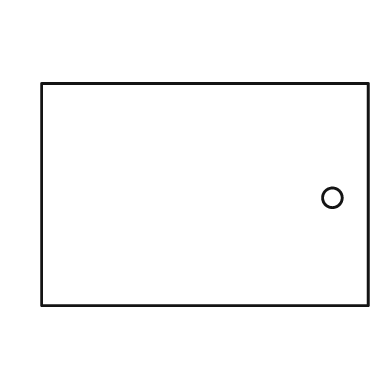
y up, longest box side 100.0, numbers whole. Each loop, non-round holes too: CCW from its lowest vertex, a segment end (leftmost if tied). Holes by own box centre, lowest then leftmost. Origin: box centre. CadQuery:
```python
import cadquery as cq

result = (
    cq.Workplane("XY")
    .moveTo(-50.0, -34.0)
    .lineTo(50.0, -34.0)
    .lineTo(50.0, 34.0)
    .lineTo(-50.0, 34.0)
    .close()
    .moveTo(39.0, -1.0)
    .circle(3.0)
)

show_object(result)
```